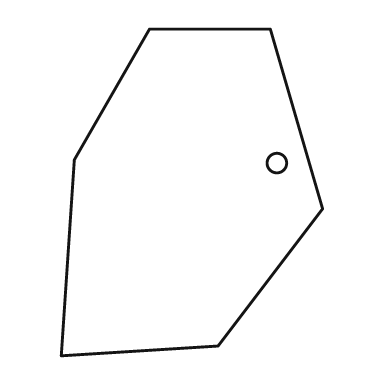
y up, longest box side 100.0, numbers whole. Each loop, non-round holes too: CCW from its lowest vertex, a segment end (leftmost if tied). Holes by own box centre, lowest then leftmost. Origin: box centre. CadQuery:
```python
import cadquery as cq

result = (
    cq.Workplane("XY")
    .moveTo(-40.0, -50.0)
    .lineTo(8.0, -47.0)
    .lineTo(40.0, -5.0)
    .lineTo(24.0, 50.0)
    .lineTo(-13.0, 50.0)
    .lineTo(-36.0, 10.0)
    .close()
    .moveTo(26.0, 9.0)
    .circle(3.0)
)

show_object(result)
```